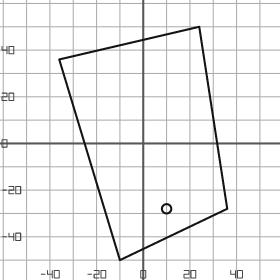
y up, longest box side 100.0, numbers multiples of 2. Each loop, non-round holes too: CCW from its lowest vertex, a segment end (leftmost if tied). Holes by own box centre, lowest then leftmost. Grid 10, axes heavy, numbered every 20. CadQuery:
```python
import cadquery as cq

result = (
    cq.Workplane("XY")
    .moveTo(-10.0, -50.0)
    .lineTo(36.0, -28.0)
    .lineTo(24.0, 50.0)
    .lineTo(-36.0, 36.0)
    .close()
    .moveTo(10.0, -28.0)
    .circle(2.0)
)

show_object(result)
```